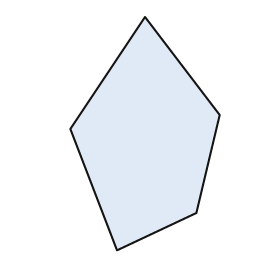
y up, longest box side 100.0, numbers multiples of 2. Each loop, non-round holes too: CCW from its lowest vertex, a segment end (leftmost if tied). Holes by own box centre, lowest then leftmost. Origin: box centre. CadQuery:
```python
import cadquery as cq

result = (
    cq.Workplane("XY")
    .moveTo(-12.0, -50.0)
    .lineTo(22.0, -34.0)
    .lineTo(32.0, 8.0)
    .lineTo(0.0, 50.0)
    .lineTo(-32.0, 2.0)
    .close()
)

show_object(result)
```